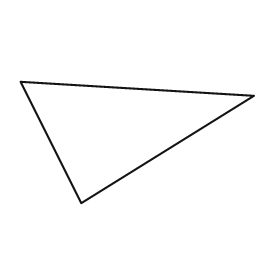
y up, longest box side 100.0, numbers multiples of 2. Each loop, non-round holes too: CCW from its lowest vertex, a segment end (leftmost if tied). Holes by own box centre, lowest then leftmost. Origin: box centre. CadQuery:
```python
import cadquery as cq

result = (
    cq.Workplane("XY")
    .moveTo(-24.0, -26.0)
    .lineTo(50.0, 20.0)
    .lineTo(-50.0, 26.0)
    .close()
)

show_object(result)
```